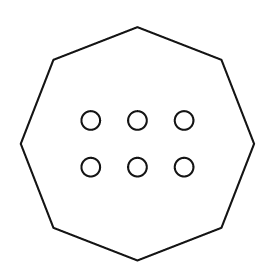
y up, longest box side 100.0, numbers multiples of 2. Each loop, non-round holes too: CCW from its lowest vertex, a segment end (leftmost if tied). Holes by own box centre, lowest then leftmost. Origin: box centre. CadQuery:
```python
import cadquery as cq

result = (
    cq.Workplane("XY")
    .moveTo(0.0, -50.0)
    .lineTo(36.0, -36.0)
    .lineTo(50.0, 0.0)
    .lineTo(36.0, 36.0)
    .lineTo(0.0, 50.0)
    .lineTo(-36.0, 36.0)
    .lineTo(-50.0, 0.0)
    .lineTo(-36.0, -36.0)
    .close()
    .moveTo(-20.0, -10.0)
    .circle(4.0)
    .moveTo(0.0, -10.0)
    .circle(4.0)
    .moveTo(20.0, -10.0)
    .circle(4.0)
    .moveTo(-20.0, 10.0)
    .circle(4.0)
    .moveTo(0.0, 10.0)
    .circle(4.0)
    .moveTo(20.0, 10.0)
    .circle(4.0)
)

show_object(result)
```